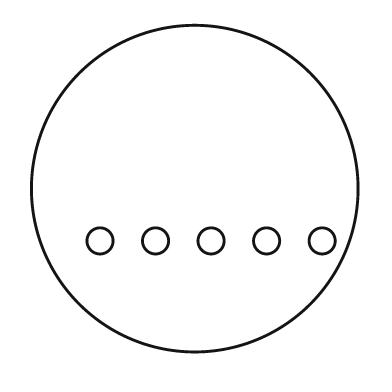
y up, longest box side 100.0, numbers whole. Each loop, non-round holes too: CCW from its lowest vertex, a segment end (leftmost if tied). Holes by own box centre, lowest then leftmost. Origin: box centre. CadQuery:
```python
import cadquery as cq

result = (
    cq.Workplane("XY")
    .moveTo(0.0, 0.0)
    .circle(50.0)
    .moveTo(-29.0, -16.0)
    .circle(4.0)
    .moveTo(-12.0, -16.0)
    .circle(4.0)
    .moveTo(5.0, -16.0)
    .circle(4.0)
    .moveTo(22.0, -16.0)
    .circle(4.0)
    .moveTo(39.0, -16.0)
    .circle(4.0)
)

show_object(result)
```